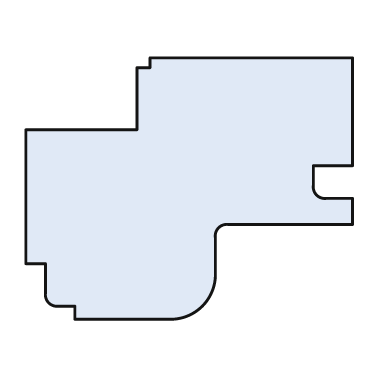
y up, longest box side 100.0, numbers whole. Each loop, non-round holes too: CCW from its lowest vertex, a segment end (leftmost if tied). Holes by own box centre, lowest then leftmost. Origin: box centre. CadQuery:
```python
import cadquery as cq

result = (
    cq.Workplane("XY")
    .moveTo(-35.0, -40.0)
    .lineTo(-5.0, -40.0)
    .threePointArc((4.0, -36.0), (8.0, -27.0))
    .lineTo(8.0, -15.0)
    .threePointArc((9.0, -12.0), (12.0, -11.0))
    .lineTo(50.0, -11.0)
    .lineTo(50.0, -3.0)
    .lineTo(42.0, -3.0)
    .threePointArc((39.0, -2.0), (38.0, 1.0))
    .lineTo(38.0, 7.0)
    .lineTo(50.0, 7.0)
    .lineTo(50.0, 40.0)
    .lineTo(-12.0, 40.0)
    .lineTo(-12.0, 37.0)
    .lineTo(-16.0, 37.0)
    .lineTo(-16.0, 18.0)
    .lineTo(-50.0, 18.0)
    .lineTo(-50.0, -23.0)
    .lineTo(-44.0, -23.0)
    .lineTo(-44.0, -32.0)
    .threePointArc((-43.0, -35.0), (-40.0, -36.0))
    .lineTo(-35.0, -36.0)
    .close()
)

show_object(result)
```